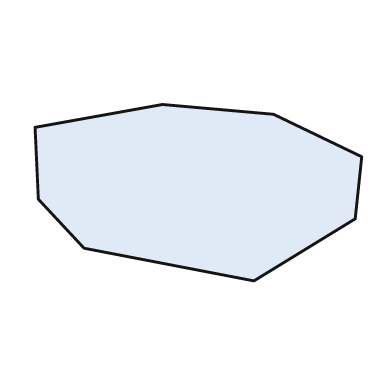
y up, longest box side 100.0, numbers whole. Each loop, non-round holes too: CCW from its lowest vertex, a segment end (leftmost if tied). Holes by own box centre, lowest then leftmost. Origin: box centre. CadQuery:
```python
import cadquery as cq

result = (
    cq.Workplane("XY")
    .moveTo(17.0, -27.0)
    .lineTo(48.0, -8.0)
    .lineTo(50.0, 11.0)
    .lineTo(23.0, 24.0)
    .lineTo(-11.0, 27.0)
    .lineTo(-50.0, 20.0)
    .lineTo(-49.0, -2.0)
    .lineTo(-35.0, -17.0)
    .close()
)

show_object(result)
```